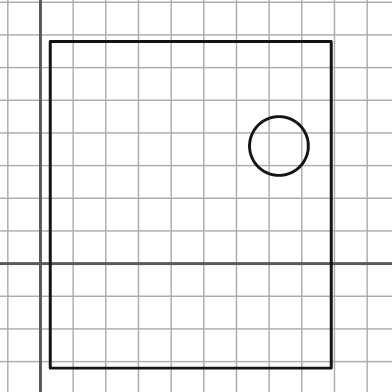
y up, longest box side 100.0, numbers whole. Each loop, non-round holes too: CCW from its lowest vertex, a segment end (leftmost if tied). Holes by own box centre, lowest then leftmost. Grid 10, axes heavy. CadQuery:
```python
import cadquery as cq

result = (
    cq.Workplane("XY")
    .moveTo(3.0, -32.0)
    .lineTo(89.0, -32.0)
    .lineTo(89.0, 68.0)
    .lineTo(3.0, 68.0)
    .close()
    .moveTo(73.0, 36.0)
    .circle(9.0)
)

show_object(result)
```